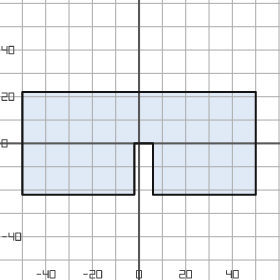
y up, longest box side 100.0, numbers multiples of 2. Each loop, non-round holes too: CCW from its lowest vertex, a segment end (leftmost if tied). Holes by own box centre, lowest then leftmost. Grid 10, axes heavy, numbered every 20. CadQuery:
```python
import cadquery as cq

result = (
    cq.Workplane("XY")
    .moveTo(-50.0, -22.0)
    .lineTo(-2.0, -22.0)
    .lineTo(-2.0, 0.0)
    .lineTo(6.0, 0.0)
    .lineTo(6.0, -22.0)
    .lineTo(50.0, -22.0)
    .lineTo(50.0, 22.0)
    .lineTo(-50.0, 22.0)
    .close()
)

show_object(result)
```